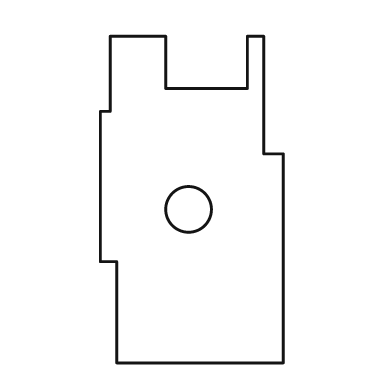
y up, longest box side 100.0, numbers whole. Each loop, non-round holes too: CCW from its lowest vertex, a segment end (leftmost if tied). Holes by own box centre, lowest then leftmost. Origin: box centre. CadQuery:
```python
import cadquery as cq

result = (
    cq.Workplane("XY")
    .moveTo(-23.0, -50.0)
    .lineTo(28.0, -50.0)
    .lineTo(28.0, 14.0)
    .lineTo(22.0, 14.0)
    .lineTo(22.0, 50.0)
    .lineTo(17.0, 50.0)
    .lineTo(17.0, 34.0)
    .lineTo(-8.0, 34.0)
    .lineTo(-8.0, 50.0)
    .lineTo(-25.0, 50.0)
    .lineTo(-25.0, 27.0)
    .lineTo(-28.0, 27.0)
    .lineTo(-28.0, -19.0)
    .lineTo(-23.0, -19.0)
    .close()
    .moveTo(-1.0, -3.0)
    .circle(7.0)
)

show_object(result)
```